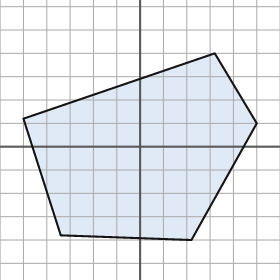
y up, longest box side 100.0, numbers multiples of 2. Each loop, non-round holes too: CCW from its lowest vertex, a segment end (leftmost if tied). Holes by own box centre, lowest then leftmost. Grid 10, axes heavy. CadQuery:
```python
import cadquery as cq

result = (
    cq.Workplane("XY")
    .moveTo(22.0, -40.0)
    .lineTo(50.0, 10.0)
    .lineTo(32.0, 40.0)
    .lineTo(-50.0, 12.0)
    .lineTo(-34.0, -38.0)
    .close()
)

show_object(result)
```